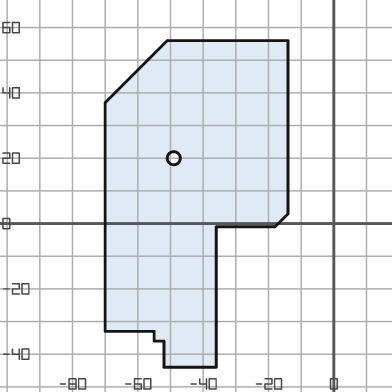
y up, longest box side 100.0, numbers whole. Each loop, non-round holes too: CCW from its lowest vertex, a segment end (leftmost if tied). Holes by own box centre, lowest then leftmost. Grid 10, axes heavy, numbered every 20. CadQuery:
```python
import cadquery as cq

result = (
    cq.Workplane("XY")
    .moveTo(-52.0, -44.0)
    .lineTo(-36.0, -44.0)
    .lineTo(-36.0, -1.0)
    .lineTo(-18.0, -1.0)
    .lineTo(-14.0, 3.0)
    .lineTo(-14.0, 56.0)
    .lineTo(-51.0, 56.0)
    .lineTo(-70.0, 37.0)
    .lineTo(-70.0, -33.0)
    .lineTo(-55.0, -33.0)
    .lineTo(-55.0, -36.0)
    .lineTo(-52.0, -36.0)
    .close()
    .moveTo(-49.0, 20.0)
    .circle(2.0)
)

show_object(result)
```